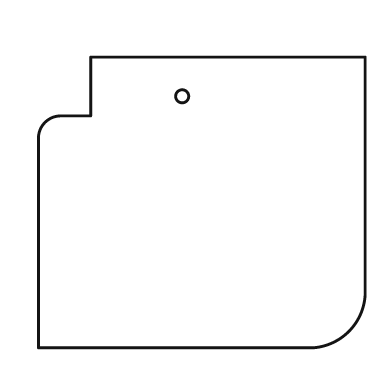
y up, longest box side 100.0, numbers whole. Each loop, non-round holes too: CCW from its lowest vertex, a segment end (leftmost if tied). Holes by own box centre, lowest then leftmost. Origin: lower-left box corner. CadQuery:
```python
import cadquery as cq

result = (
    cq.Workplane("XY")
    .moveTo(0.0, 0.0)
    .lineTo(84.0, 0.0)
    .threePointArc((95.0, 5.0), (100.0, 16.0))
    .lineTo(100.0, 89.0)
    .lineTo(16.0, 89.0)
    .lineTo(16.0, 71.0)
    .lineTo(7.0, 71.0)
    .threePointArc((2.0, 69.0), (0.0, 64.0))
    .close()
    .moveTo(44.0, 77.0)
    .circle(2.0)
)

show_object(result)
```